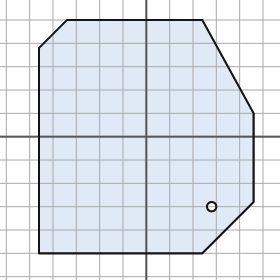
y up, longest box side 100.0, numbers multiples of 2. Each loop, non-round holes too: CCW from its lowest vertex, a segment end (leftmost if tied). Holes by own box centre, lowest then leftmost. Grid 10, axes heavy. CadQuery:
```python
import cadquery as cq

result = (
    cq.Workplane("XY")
    .moveTo(-46.0, -50.0)
    .lineTo(24.0, -50.0)
    .lineTo(46.0, -28.0)
    .lineTo(46.0, 10.0)
    .lineTo(24.0, 50.0)
    .lineTo(-34.0, 50.0)
    .lineTo(-46.0, 38.0)
    .close()
    .moveTo(28.0, -30.0)
    .circle(2.0)
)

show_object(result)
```